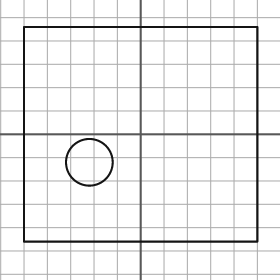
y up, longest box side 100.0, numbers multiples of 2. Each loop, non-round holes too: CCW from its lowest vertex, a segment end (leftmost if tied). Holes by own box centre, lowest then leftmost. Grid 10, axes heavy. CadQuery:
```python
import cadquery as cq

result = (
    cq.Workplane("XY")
    .moveTo(-50.0, -46.0)
    .lineTo(50.0, -46.0)
    .lineTo(50.0, 46.0)
    .lineTo(-50.0, 46.0)
    .close()
    .moveTo(-22.0, -12.0)
    .circle(10.0)
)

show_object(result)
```